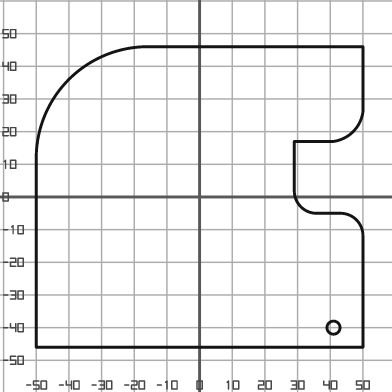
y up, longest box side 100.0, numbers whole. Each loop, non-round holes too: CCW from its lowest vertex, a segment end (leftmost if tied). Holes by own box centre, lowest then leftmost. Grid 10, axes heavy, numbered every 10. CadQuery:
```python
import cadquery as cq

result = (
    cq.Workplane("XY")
    .moveTo(-50.0, -46.0)
    .lineTo(50.0, -46.0)
    .lineTo(50.0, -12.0)
    .threePointArc((48.0, -7.0), (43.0, -5.0))
    .lineTo(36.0, -5.0)
    .threePointArc((31.0, -3.0), (29.0, 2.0))
    .lineTo(29.0, 17.0)
    .lineTo(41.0, 17.0)
    .threePointArc((47.0, 20.0), (50.0, 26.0))
    .lineTo(50.0, 46.0)
    .lineTo(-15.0, 46.0)
    .threePointArc((-40.0, 36.0), (-50.0, 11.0))
    .close()
    .moveTo(41.0, -40.0)
    .circle(2.0)
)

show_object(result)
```